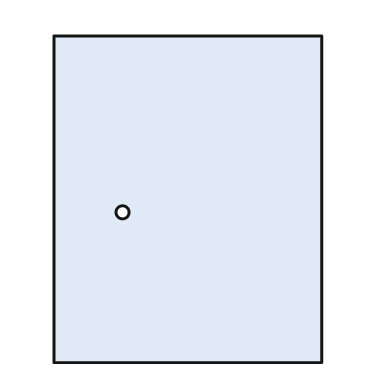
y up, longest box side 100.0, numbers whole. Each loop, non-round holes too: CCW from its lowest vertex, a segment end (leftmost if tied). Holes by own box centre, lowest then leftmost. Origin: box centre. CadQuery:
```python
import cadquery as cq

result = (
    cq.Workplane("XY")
    .moveTo(-41.0, -50.0)
    .lineTo(41.0, -50.0)
    .lineTo(41.0, 50.0)
    .lineTo(-41.0, 50.0)
    .close()
    .moveTo(-20.0, -4.0)
    .circle(2.0)
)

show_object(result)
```